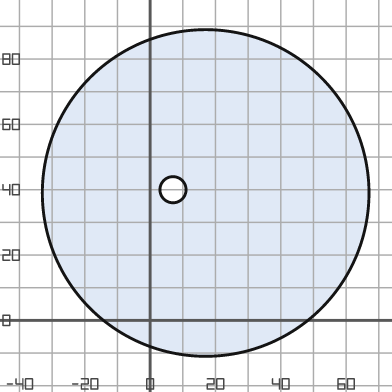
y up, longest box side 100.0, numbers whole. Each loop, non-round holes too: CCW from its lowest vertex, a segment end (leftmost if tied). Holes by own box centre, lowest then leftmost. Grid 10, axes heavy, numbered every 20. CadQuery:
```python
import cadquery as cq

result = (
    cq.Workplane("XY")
    .moveTo(17.0, 39.0)
    .circle(50.0)
    .moveTo(7.0, 40.0)
    .circle(4.0)
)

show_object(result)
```